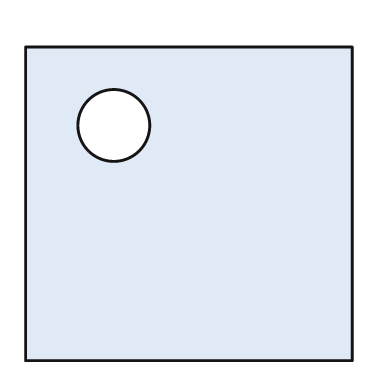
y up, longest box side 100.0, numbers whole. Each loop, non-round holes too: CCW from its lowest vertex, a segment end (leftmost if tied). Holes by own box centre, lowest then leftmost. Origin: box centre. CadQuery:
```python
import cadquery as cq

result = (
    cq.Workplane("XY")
    .moveTo(-50.0, -48.0)
    .lineTo(50.0, -48.0)
    .lineTo(50.0, 48.0)
    .lineTo(-50.0, 48.0)
    .close()
    .moveTo(-23.0, 24.0)
    .circle(11.0)
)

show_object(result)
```